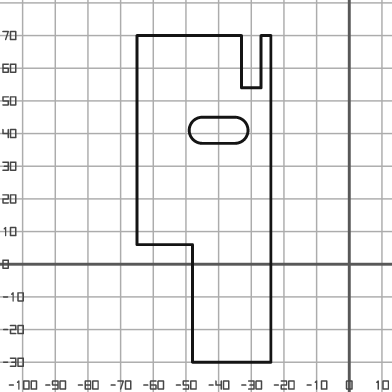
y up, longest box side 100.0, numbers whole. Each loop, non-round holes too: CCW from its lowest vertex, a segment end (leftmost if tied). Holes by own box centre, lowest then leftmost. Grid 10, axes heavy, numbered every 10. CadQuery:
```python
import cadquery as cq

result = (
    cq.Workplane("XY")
    .moveTo(-48.0, -30.0)
    .lineTo(-24.0, -30.0)
    .lineTo(-24.0, 70.0)
    .lineTo(-27.0, 70.0)
    .lineTo(-27.0, 54.0)
    .lineTo(-33.0, 54.0)
    .lineTo(-33.0, 70.0)
    .lineTo(-65.0, 70.0)
    .lineTo(-65.0, 6.0)
    .lineTo(-48.0, 6.0)
    .close()
    .moveTo(-45.0, 37.0)
    .lineTo(-35.0, 37.0)
    .threePointArc((-31.0, 41.0), (-35.0, 45.0))
    .lineTo(-45.0, 45.0)
    .threePointArc((-49.0, 41.0), (-45.0, 37.0))
    .close()
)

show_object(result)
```